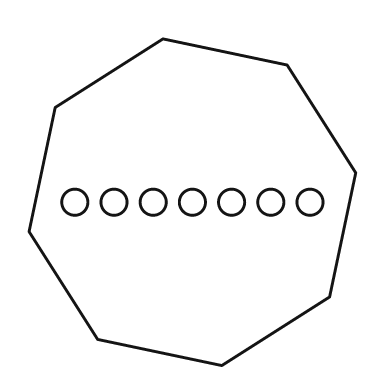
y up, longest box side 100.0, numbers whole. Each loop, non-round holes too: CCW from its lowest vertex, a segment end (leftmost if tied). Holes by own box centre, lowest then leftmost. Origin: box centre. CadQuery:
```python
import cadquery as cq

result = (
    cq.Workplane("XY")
    .moveTo(9.0, -50.0)
    .lineTo(42.0, -29.0)
    .lineTo(50.0, 9.0)
    .lineTo(29.0, 42.0)
    .lineTo(-9.0, 50.0)
    .lineTo(-42.0, 29.0)
    .lineTo(-50.0, -9.0)
    .lineTo(-29.0, -42.0)
    .close()
    .moveTo(-36.0, 0.0)
    .circle(4.0)
    .moveTo(-24.0, 0.0)
    .circle(4.0)
    .moveTo(-12.0, 0.0)
    .circle(4.0)
    .moveTo(0.0, 0.0)
    .circle(4.0)
    .moveTo(12.0, 0.0)
    .circle(4.0)
    .moveTo(24.0, 0.0)
    .circle(4.0)
    .moveTo(36.0, 0.0)
    .circle(4.0)
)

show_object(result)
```